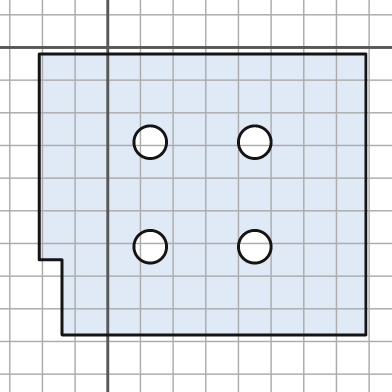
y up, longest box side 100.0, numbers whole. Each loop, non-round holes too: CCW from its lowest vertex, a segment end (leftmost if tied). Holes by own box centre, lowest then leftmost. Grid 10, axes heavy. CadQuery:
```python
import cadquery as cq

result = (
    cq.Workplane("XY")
    .moveTo(-14.0, -88.0)
    .lineTo(79.0, -88.0)
    .lineTo(79.0, -2.0)
    .lineTo(-21.0, -2.0)
    .lineTo(-21.0, -65.0)
    .lineTo(-14.0, -65.0)
    .close()
    .moveTo(13.0, -61.0)
    .circle(5.0)
    .moveTo(45.0, -61.0)
    .circle(5.0)
    .moveTo(13.0, -29.0)
    .circle(5.0)
    .moveTo(45.0, -29.0)
    .circle(5.0)
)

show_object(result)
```